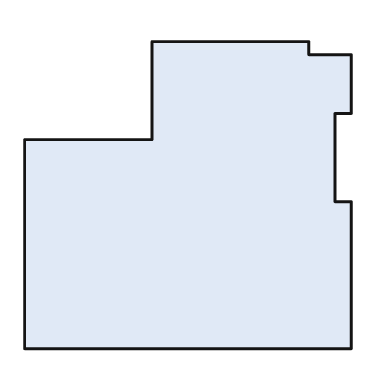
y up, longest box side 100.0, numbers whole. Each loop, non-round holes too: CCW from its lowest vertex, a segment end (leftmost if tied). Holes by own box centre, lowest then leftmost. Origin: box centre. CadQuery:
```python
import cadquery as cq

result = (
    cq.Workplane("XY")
    .moveTo(-50.0, -47.0)
    .lineTo(50.0, -47.0)
    .lineTo(50.0, -2.0)
    .lineTo(45.0, -2.0)
    .lineTo(45.0, 25.0)
    .lineTo(50.0, 25.0)
    .lineTo(50.0, 43.0)
    .lineTo(37.0, 43.0)
    .lineTo(37.0, 47.0)
    .lineTo(-11.0, 47.0)
    .lineTo(-11.0, 17.0)
    .lineTo(-50.0, 17.0)
    .close()
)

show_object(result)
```